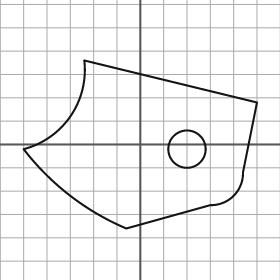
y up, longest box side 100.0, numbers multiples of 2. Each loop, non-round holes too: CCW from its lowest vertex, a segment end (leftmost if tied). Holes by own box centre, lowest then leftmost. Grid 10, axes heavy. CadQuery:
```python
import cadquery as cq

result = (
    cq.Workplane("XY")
    .moveTo(-6.0, -36.0)
    .lineTo(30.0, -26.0)
    .threePointArc((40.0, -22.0), (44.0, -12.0))
    .lineTo(50.0, 18.0)
    .lineTo(-24.0, 36.0)
    .threePointArc((-30.0, 12.0), (-50.0, -2.0))
    .threePointArc((-30.0, -22.0), (-6.0, -36.0))
    .close()
    .moveTo(20.0, -2.0)
    .circle(8.0)
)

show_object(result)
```